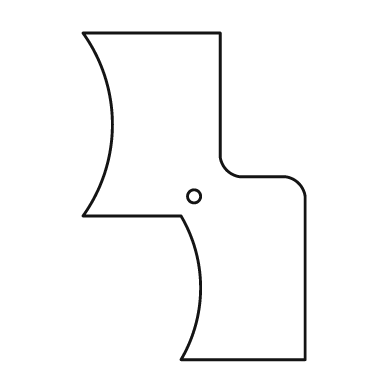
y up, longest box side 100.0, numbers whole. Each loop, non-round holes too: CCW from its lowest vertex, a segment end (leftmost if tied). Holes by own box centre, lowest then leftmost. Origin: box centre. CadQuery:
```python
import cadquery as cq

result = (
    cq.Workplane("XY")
    .moveTo(-4.0, -50.0)
    .lineTo(34.0, -50.0)
    .lineTo(34.0, 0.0)
    .threePointArc((32.0, 4.0), (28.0, 6.0))
    .lineTo(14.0, 6.0)
    .threePointArc((10.0, 8.0), (8.0, 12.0))
    .lineTo(8.0, 50.0)
    .lineTo(-34.0, 50.0)
    .threePointArc((-25.0, 22.0), (-34.0, -6.0))
    .lineTo(-4.0, -6.0)
    .threePointArc((2.0, -28.0), (-4.0, -50.0))
    .close()
    .moveTo(0.0, 0.0)
    .circle(2.0)
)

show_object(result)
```